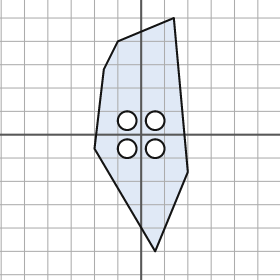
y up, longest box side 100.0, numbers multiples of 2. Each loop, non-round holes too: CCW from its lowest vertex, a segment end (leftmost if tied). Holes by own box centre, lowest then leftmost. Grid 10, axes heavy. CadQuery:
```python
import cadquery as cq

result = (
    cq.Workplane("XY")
    .moveTo(6.0, -50.0)
    .lineTo(20.0, -16.0)
    .lineTo(14.0, 50.0)
    .lineTo(-10.0, 40.0)
    .lineTo(-16.0, 28.0)
    .lineTo(-20.0, -6.0)
    .close()
    .moveTo(-6.0, -6.0)
    .circle(4.0)
    .moveTo(6.0, -6.0)
    .circle(4.0)
    .moveTo(-6.0, 6.0)
    .circle(4.0)
    .moveTo(6.0, 6.0)
    .circle(4.0)
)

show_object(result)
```